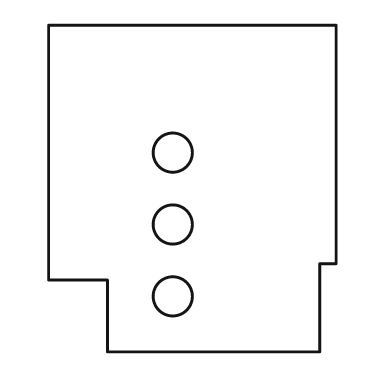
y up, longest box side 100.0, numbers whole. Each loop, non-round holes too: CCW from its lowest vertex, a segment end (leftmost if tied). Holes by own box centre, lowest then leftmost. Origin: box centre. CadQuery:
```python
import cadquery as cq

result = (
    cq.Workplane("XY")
    .moveTo(-26.0, -50.0)
    .lineTo(39.0, -50.0)
    .lineTo(39.0, -23.0)
    .lineTo(44.0, -23.0)
    .lineTo(44.0, 50.0)
    .lineTo(-44.0, 50.0)
    .lineTo(-44.0, -28.0)
    .lineTo(-26.0, -28.0)
    .close()
    .moveTo(-6.0, -33.0)
    .circle(6.0)
    .moveTo(-6.0, -11.0)
    .circle(6.0)
    .moveTo(-6.0, 11.0)
    .circle(6.0)
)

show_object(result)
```